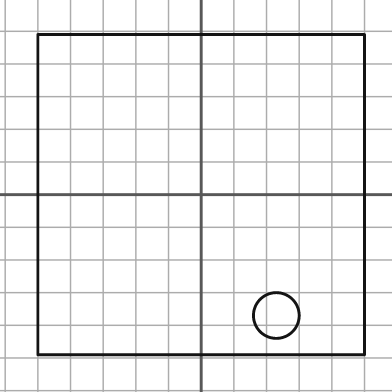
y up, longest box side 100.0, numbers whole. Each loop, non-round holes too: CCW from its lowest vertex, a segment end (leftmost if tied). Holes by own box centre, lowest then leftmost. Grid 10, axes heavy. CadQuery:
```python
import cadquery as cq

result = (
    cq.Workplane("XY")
    .moveTo(-50.0, -49.0)
    .lineTo(50.0, -49.0)
    .lineTo(50.0, 49.0)
    .lineTo(-50.0, 49.0)
    .close()
    .moveTo(23.0, -37.0)
    .circle(7.0)
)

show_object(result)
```